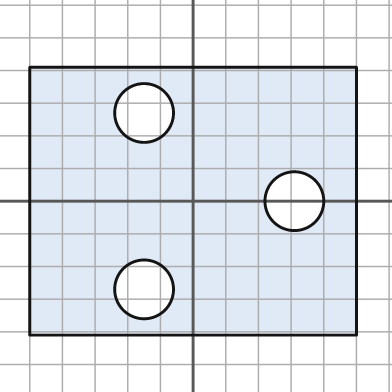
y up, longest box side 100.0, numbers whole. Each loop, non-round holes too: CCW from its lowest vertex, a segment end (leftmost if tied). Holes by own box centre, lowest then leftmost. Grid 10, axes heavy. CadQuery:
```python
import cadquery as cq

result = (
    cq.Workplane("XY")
    .moveTo(-50.0, -41.0)
    .lineTo(50.0, -41.0)
    .lineTo(50.0, 41.0)
    .lineTo(-50.0, 41.0)
    .close()
    .moveTo(-15.0, -27.0)
    .circle(9.0)
    .moveTo(31.0, 0.0)
    .circle(9.0)
    .moveTo(-15.0, 27.0)
    .circle(9.0)
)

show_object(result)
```